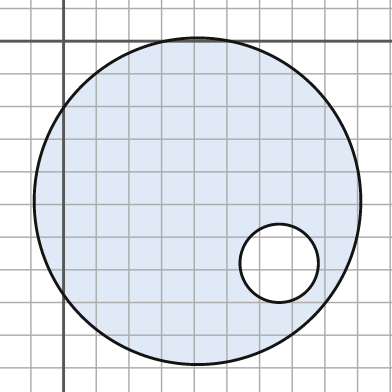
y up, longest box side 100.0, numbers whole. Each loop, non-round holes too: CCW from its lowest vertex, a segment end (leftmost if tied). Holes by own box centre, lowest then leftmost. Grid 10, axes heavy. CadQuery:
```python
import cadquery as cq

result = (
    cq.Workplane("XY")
    .moveTo(41.0, -49.0)
    .circle(50.0)
    .moveTo(66.0, -68.0)
    .circle(12.0)
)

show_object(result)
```